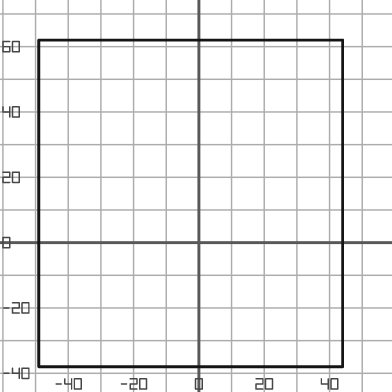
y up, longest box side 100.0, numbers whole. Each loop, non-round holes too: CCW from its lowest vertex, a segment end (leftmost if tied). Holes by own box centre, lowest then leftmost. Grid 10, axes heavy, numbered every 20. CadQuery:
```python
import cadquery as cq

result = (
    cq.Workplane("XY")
    .moveTo(-49.0, -38.0)
    .lineTo(44.0, -38.0)
    .lineTo(44.0, 62.0)
    .lineTo(-49.0, 62.0)
    .close()
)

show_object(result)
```